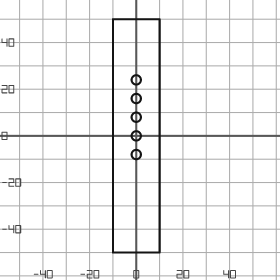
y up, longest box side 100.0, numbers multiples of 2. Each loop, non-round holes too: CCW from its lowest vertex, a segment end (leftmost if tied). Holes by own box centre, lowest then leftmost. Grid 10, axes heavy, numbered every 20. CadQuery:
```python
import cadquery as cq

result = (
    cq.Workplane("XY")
    .moveTo(-10.0, -50.0)
    .lineTo(10.0, -50.0)
    .lineTo(10.0, 50.0)
    .lineTo(-10.0, 50.0)
    .close()
    .moveTo(0.0, -8.0)
    .circle(2.0)
    .moveTo(0.0, 0.0)
    .circle(2.0)
    .moveTo(0.0, 8.0)
    .circle(2.0)
    .moveTo(0.0, 16.0)
    .circle(2.0)
    .moveTo(0.0, 24.0)
    .circle(2.0)
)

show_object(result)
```